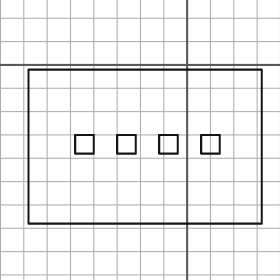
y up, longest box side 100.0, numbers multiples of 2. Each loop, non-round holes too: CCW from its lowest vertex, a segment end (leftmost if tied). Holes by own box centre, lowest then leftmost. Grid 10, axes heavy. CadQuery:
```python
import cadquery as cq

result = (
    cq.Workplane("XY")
    .moveTo(-68.0, -68.0)
    .lineTo(32.0, -68.0)
    .lineTo(32.0, -2.0)
    .lineTo(-68.0, -2.0)
    .close()
    .moveTo(-48.0, -38.0)
    .lineTo(-40.0, -38.0)
    .lineTo(-40.0, -30.0)
    .lineTo(-48.0, -30.0)
    .close()
    .moveTo(-30.0, -38.0)
    .lineTo(-22.0, -38.0)
    .lineTo(-22.0, -30.0)
    .lineTo(-30.0, -30.0)
    .close()
    .moveTo(-12.0, -38.0)
    .lineTo(-4.0, -38.0)
    .lineTo(-4.0, -30.0)
    .lineTo(-12.0, -30.0)
    .close()
    .moveTo(6.0, -38.0)
    .lineTo(14.0, -38.0)
    .lineTo(14.0, -30.0)
    .lineTo(6.0, -30.0)
    .close()
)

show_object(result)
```